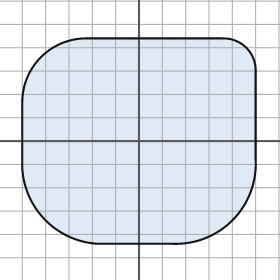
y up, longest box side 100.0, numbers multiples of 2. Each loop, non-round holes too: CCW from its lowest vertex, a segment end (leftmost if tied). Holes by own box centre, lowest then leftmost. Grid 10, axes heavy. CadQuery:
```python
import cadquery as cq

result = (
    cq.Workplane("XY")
    .moveTo(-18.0, -44.0)
    .lineTo(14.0, -44.0)
    .threePointArc((40.0, -34.0), (50.0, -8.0))
    .lineTo(50.0, 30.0)
    .threePointArc((46.0, 40.0), (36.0, 44.0))
    .lineTo(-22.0, 44.0)
    .threePointArc((-42.0, 36.0), (-50.0, 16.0))
    .lineTo(-50.0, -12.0)
    .threePointArc((-40.0, -34.0), (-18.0, -44.0))
    .close()
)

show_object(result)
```